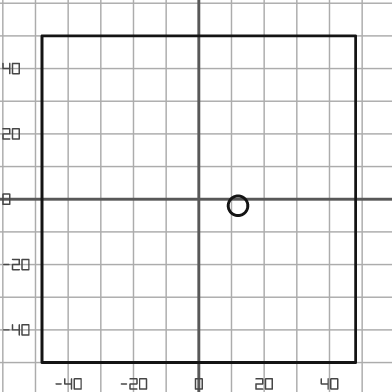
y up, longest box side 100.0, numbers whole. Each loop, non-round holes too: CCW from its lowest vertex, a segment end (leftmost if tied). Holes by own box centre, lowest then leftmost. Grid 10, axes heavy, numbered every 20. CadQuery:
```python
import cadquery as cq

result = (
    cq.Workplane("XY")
    .moveTo(-48.0, -50.0)
    .lineTo(48.0, -50.0)
    .lineTo(48.0, 50.0)
    .lineTo(-48.0, 50.0)
    .close()
    .moveTo(12.0, -2.0)
    .circle(3.0)
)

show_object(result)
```